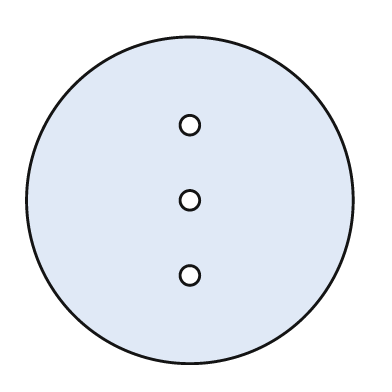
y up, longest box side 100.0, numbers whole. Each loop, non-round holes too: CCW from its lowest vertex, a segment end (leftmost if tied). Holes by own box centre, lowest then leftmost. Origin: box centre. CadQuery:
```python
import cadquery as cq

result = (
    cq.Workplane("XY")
    .moveTo(0.0, 0.0)
    .circle(50.0)
    .moveTo(0.0, -23.0)
    .circle(3.0)
    .moveTo(0.0, 0.0)
    .circle(3.0)
    .moveTo(0.0, 23.0)
    .circle(3.0)
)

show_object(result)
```